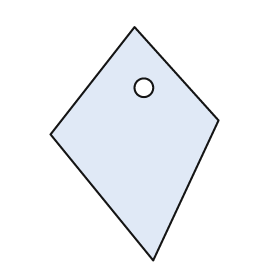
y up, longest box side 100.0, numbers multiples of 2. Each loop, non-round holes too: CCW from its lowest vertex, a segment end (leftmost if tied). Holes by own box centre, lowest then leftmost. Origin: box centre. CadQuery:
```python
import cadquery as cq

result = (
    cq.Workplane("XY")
    .moveTo(8.0, -50.0)
    .lineTo(36.0, 10.0)
    .lineTo(0.0, 50.0)
    .lineTo(-36.0, 4.0)
    .close()
    .moveTo(4.0, 24.0)
    .circle(4.0)
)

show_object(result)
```